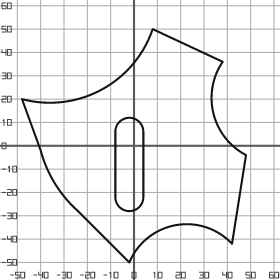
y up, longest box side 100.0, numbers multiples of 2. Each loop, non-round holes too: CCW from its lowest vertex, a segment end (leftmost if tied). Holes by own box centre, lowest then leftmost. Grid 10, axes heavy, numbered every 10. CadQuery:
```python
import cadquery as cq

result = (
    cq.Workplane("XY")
    .moveTo(-2.0, -50.0)
    .threePointArc((18.0, -34.0), (42.0, -42.0))
    .lineTo(48.0, -4.0)
    .threePointArc((34.0, 14.0), (38.0, 36.0))
    .lineTo(8.0, 50.0)
    .threePointArc((-14.0, 24.0), (-48.0, 20.0))
    .lineTo(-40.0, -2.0)
    .threePointArc((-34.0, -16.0), (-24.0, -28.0))
    .close()
    .moveTo(-8.0, -22.0)
    .threePointArc((-2.0, -28.0), (4.0, -22.0))
    .lineTo(4.0, 6.0)
    .threePointArc((-2.0, 12.0), (-8.0, 6.0))
    .close()
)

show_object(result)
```